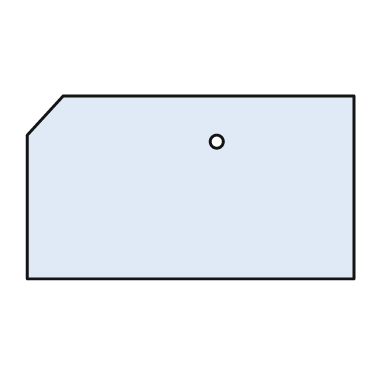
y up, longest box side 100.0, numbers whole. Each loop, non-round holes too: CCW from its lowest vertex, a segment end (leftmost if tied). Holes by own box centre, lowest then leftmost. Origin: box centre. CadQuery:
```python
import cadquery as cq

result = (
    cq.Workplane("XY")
    .moveTo(-50.0, -28.0)
    .lineTo(50.0, -28.0)
    .lineTo(50.0, 28.0)
    .lineTo(-39.0, 28.0)
    .lineTo(-50.0, 16.0)
    .close()
    .moveTo(8.0, 14.0)
    .circle(2.0)
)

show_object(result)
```